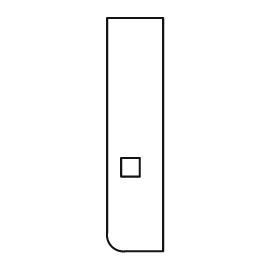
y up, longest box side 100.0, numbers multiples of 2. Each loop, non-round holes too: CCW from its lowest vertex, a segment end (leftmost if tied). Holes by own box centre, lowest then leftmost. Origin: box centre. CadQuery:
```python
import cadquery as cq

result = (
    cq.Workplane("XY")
    .moveTo(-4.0, -50.0)
    .lineTo(12.0, -50.0)
    .lineTo(12.0, 50.0)
    .lineTo(-12.0, 50.0)
    .lineTo(-12.0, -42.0)
    .threePointArc((-10.0, -48.0), (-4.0, -50.0))
    .close()
    .moveTo(-6.0, -18.0)
    .lineTo(2.0, -18.0)
    .lineTo(2.0, -10.0)
    .lineTo(-6.0, -10.0)
    .close()
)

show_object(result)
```